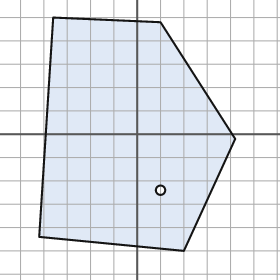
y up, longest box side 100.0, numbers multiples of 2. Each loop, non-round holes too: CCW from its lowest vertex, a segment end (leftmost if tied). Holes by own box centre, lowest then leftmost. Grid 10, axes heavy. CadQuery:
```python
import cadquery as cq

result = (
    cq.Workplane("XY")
    .moveTo(20.0, -50.0)
    .lineTo(42.0, -2.0)
    .lineTo(10.0, 48.0)
    .lineTo(-36.0, 50.0)
    .lineTo(-42.0, -44.0)
    .close()
    .moveTo(10.0, -24.0)
    .circle(2.0)
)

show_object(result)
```